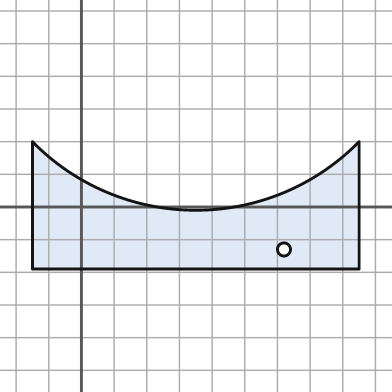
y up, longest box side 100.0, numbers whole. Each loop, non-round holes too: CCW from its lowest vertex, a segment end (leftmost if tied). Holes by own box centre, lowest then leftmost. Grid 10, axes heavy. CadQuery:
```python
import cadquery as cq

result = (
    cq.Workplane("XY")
    .moveTo(-15.0, -19.0)
    .lineTo(85.0, -19.0)
    .lineTo(85.0, 20.0)
    .threePointArc((35.0, -1.0), (-15.0, 20.0))
    .close()
    .moveTo(62.0, -13.0)
    .circle(2.0)
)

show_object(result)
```